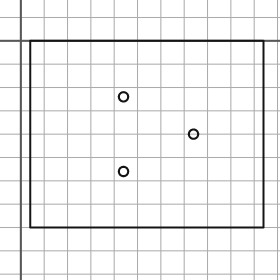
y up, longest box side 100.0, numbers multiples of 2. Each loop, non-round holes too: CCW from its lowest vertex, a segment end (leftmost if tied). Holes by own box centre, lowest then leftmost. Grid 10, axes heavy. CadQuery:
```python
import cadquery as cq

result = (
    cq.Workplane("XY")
    .moveTo(4.0, -80.0)
    .lineTo(104.0, -80.0)
    .lineTo(104.0, 0.0)
    .lineTo(4.0, 0.0)
    .close()
    .moveTo(44.0, -56.0)
    .circle(2.0)
    .moveTo(74.0, -40.0)
    .circle(2.0)
    .moveTo(44.0, -24.0)
    .circle(2.0)
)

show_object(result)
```